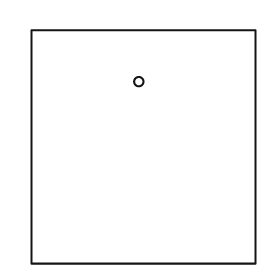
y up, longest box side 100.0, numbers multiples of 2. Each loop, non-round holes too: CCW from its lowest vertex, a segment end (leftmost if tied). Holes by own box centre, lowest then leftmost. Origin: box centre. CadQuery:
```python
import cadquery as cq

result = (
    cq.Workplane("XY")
    .moveTo(-48.0, -50.0)
    .lineTo(48.0, -50.0)
    .lineTo(48.0, 50.0)
    .lineTo(-48.0, 50.0)
    .close()
    .moveTo(-2.0, 28.0)
    .circle(2.0)
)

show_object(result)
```